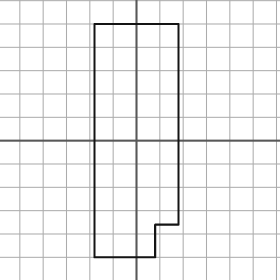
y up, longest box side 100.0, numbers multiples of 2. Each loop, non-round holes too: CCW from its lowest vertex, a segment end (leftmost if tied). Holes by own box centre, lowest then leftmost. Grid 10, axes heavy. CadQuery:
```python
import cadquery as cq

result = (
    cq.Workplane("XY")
    .moveTo(-18.0, -50.0)
    .lineTo(8.0, -50.0)
    .lineTo(8.0, -36.0)
    .lineTo(18.0, -36.0)
    .lineTo(18.0, 50.0)
    .lineTo(-18.0, 50.0)
    .close()
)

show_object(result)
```